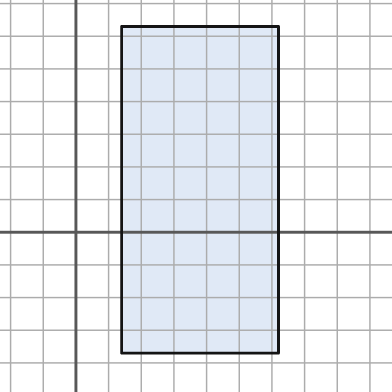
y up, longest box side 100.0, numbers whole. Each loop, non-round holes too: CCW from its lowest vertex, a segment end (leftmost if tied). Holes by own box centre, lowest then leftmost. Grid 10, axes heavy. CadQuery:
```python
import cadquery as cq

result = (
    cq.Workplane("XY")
    .moveTo(14.0, -37.0)
    .lineTo(62.0, -37.0)
    .lineTo(62.0, 63.0)
    .lineTo(14.0, 63.0)
    .close()
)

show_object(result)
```